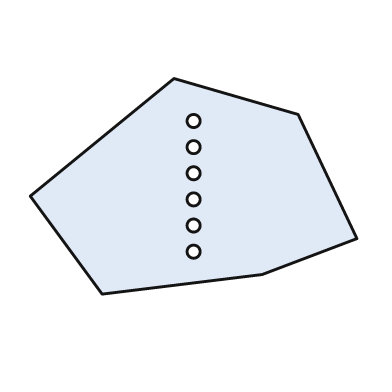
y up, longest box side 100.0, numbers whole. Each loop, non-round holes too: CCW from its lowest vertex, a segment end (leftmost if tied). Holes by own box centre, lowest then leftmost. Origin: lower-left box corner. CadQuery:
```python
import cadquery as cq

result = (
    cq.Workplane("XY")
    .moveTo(22.0, 0.0)
    .lineTo(71.0, 6.0)
    .lineTo(100.0, 17.0)
    .lineTo(82.0, 55.0)
    .lineTo(44.0, 66.0)
    .lineTo(0.0, 30.0)
    .close()
    .moveTo(50.0, 13.0)
    .circle(2.0)
    .moveTo(50.0, 21.0)
    .circle(2.0)
    .moveTo(50.0, 29.0)
    .circle(2.0)
    .moveTo(50.0, 37.0)
    .circle(2.0)
    .moveTo(50.0, 45.0)
    .circle(2.0)
    .moveTo(50.0, 53.0)
    .circle(2.0)
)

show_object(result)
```